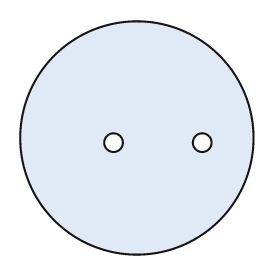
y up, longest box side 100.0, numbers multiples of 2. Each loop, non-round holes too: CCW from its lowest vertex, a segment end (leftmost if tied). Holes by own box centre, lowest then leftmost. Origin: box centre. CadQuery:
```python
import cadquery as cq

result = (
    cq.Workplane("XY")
    .moveTo(0.0, 0.0)
    .circle(50.0)
    .moveTo(-10.0, -2.0)
    .circle(4.0)
    .moveTo(28.0, -2.0)
    .circle(4.0)
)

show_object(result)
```